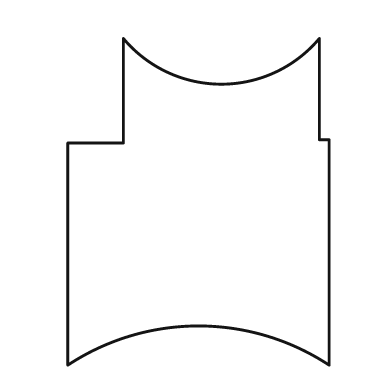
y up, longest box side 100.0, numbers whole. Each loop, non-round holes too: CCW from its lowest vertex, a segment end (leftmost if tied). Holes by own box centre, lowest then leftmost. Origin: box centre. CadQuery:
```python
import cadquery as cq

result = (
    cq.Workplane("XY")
    .moveTo(-40.0, -50.0)
    .threePointArc((0.0, -38.0), (40.0, -50.0))
    .lineTo(40.0, 19.0)
    .lineTo(37.0, 19.0)
    .lineTo(37.0, 50.0)
    .threePointArc((7.0, 36.0), (-23.0, 50.0))
    .lineTo(-23.0, 18.0)
    .lineTo(-40.0, 18.0)
    .close()
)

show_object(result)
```